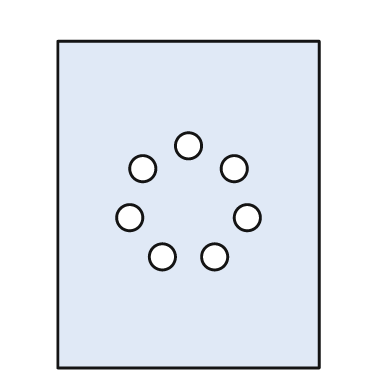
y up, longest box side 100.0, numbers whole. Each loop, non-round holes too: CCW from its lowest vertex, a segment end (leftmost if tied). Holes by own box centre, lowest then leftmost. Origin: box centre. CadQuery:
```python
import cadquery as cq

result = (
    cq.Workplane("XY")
    .moveTo(-40.0, -50.0)
    .lineTo(40.0, -50.0)
    .lineTo(40.0, 50.0)
    .lineTo(-40.0, 50.0)
    .close()
    .moveTo(-8.0, -16.0)
    .circle(4.0)
    .moveTo(8.0, -16.0)
    .circle(4.0)
    .moveTo(-18.0, -4.0)
    .circle(4.0)
    .moveTo(18.0, -4.0)
    .circle(4.0)
    .moveTo(-14.0, 11.0)
    .circle(4.0)
    .moveTo(14.0, 11.0)
    .circle(4.0)
    .moveTo(0.0, 18.0)
    .circle(4.0)
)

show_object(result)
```